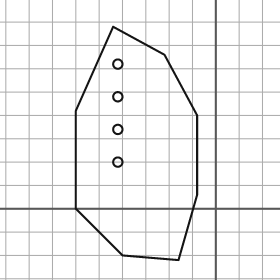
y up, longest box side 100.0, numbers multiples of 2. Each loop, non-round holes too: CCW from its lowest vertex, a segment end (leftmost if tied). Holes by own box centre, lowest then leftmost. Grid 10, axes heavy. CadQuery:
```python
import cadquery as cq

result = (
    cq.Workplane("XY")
    .moveTo(-16.0, -22.0)
    .lineTo(-8.0, 6.0)
    .lineTo(-8.0, 40.0)
    .lineTo(-22.0, 66.0)
    .lineTo(-44.0, 78.0)
    .lineTo(-60.0, 42.0)
    .lineTo(-60.0, 0.0)
    .lineTo(-40.0, -20.0)
    .close()
    .moveTo(-42.0, 20.0)
    .circle(2.0)
    .moveTo(-42.0, 34.0)
    .circle(2.0)
    .moveTo(-42.0, 48.0)
    .circle(2.0)
    .moveTo(-42.0, 62.0)
    .circle(2.0)
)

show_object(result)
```